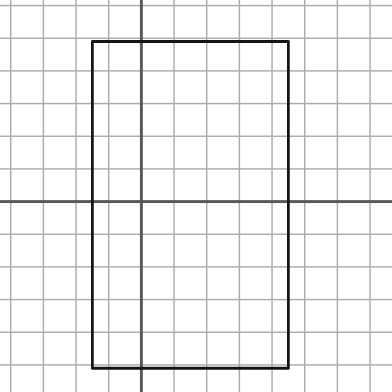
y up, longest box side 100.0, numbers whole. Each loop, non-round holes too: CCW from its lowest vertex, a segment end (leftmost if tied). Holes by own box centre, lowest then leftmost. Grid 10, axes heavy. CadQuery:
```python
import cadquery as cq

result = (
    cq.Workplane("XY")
    .moveTo(-15.0, -51.0)
    .lineTo(45.0, -51.0)
    .lineTo(45.0, 49.0)
    .lineTo(-15.0, 49.0)
    .close()
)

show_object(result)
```